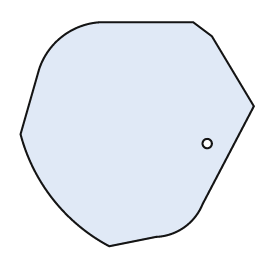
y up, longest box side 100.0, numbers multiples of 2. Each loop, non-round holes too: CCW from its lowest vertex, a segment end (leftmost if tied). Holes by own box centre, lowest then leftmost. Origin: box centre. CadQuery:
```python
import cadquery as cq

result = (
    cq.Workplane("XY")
    .moveTo(-12.0, -48.0)
    .lineTo(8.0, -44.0)
    .threePointArc((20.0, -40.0), (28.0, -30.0))
    .lineTo(50.0, 12.0)
    .lineTo(32.0, 42.0)
    .lineTo(24.0, 48.0)
    .lineTo(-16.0, 48.0)
    .threePointArc((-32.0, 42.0), (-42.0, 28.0))
    .lineTo(-50.0, 0.0)
    .threePointArc((-36.0, -28.0), (-12.0, -48.0))
    .close()
    .moveTo(30.0, -4.0)
    .circle(2.0)
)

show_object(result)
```